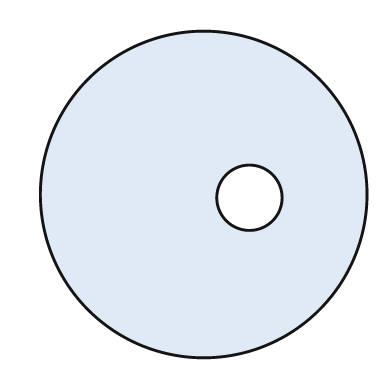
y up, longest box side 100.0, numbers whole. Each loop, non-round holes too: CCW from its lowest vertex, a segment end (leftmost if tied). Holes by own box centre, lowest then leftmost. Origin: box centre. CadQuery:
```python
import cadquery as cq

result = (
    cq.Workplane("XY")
    .moveTo(0.0, 0.0)
    .circle(50.0)
    .moveTo(14.0, -1.0)
    .circle(10.0)
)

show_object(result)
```